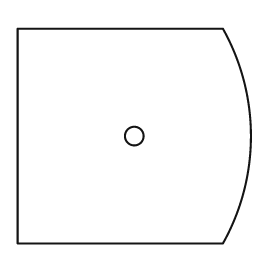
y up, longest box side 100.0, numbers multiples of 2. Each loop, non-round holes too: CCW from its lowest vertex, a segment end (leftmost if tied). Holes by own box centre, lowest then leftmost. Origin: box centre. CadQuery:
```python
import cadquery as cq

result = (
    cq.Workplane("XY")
    .moveTo(-50.0, -46.0)
    .lineTo(38.0, -46.0)
    .threePointArc((50.0, 0.0), (38.0, 46.0))
    .lineTo(-50.0, 46.0)
    .close()
    .moveTo(0.0, 0.0)
    .circle(4.0)
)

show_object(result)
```